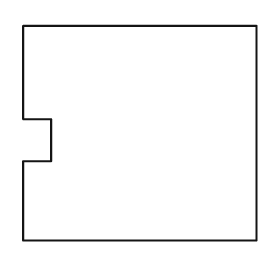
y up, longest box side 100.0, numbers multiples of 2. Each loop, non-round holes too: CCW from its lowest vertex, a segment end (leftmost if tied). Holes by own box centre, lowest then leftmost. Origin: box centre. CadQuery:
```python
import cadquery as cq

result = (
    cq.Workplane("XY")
    .moveTo(-50.0, -46.0)
    .lineTo(50.0, -46.0)
    .lineTo(50.0, 46.0)
    .lineTo(-50.0, 46.0)
    .lineTo(-50.0, 6.0)
    .lineTo(-38.0, 6.0)
    .lineTo(-38.0, -12.0)
    .lineTo(-50.0, -12.0)
    .close()
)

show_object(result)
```